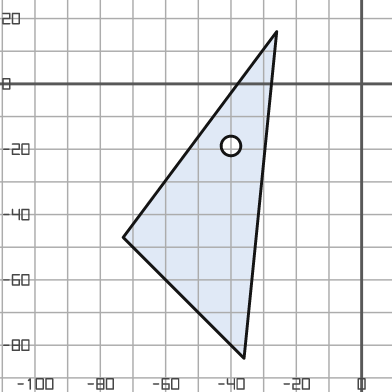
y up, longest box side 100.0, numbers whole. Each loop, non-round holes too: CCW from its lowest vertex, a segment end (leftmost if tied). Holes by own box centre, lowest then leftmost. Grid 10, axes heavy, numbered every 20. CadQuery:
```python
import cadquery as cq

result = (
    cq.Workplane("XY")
    .moveTo(-36.0, -84.0)
    .lineTo(-26.0, 16.0)
    .lineTo(-73.0, -47.0)
    .close()
    .moveTo(-40.0, -19.0)
    .circle(3.0)
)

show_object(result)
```